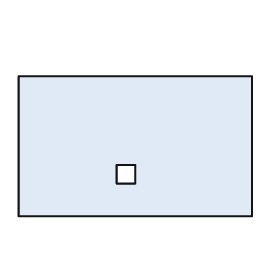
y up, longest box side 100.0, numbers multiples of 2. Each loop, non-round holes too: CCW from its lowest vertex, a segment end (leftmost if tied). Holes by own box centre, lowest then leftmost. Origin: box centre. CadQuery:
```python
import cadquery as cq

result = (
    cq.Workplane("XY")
    .moveTo(-50.0, -30.0)
    .lineTo(50.0, -30.0)
    .lineTo(50.0, 30.0)
    .lineTo(-50.0, 30.0)
    .close()
    .moveTo(-8.0, -16.0)
    .lineTo(0.0, -16.0)
    .lineTo(0.0, -8.0)
    .lineTo(-8.0, -8.0)
    .close()
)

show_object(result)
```